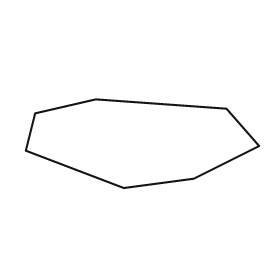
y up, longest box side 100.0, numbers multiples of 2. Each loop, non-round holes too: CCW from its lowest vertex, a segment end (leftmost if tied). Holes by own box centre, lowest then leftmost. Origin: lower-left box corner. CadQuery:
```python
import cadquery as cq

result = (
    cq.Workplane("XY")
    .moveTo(42.0, 0.0)
    .lineTo(72.0, 4.0)
    .lineTo(100.0, 18.0)
    .lineTo(86.0, 34.0)
    .lineTo(30.0, 38.0)
    .lineTo(4.0, 32.0)
    .lineTo(0.0, 16.0)
    .close()
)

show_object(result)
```